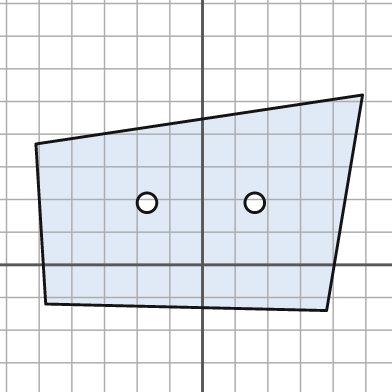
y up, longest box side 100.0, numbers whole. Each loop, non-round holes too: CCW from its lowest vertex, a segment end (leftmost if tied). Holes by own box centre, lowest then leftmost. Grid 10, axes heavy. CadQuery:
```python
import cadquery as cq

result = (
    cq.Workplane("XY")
    .moveTo(38.0, -14.0)
    .lineTo(49.0, 52.0)
    .lineTo(-51.0, 37.0)
    .lineTo(-48.0, -12.0)
    .close()
    .moveTo(-17.0, 19.0)
    .circle(3.0)
    .moveTo(16.0, 19.0)
    .circle(3.0)
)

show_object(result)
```